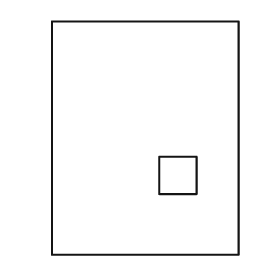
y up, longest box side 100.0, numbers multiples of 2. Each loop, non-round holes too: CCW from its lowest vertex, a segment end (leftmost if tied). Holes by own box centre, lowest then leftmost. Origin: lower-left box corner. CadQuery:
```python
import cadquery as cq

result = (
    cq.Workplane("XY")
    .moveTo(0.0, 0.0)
    .lineTo(80.0, 0.0)
    .lineTo(80.0, 100.0)
    .lineTo(0.0, 100.0)
    .close()
    .moveTo(46.0, 26.0)
    .lineTo(62.0, 26.0)
    .lineTo(62.0, 42.0)
    .lineTo(46.0, 42.0)
    .close()
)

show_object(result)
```